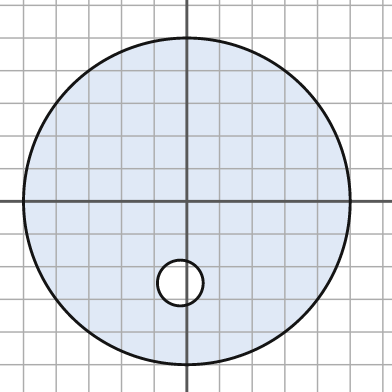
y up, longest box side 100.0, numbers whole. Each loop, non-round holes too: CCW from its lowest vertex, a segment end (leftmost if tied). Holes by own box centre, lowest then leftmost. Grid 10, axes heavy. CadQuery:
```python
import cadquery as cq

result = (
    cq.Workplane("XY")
    .moveTo(0.0, 0.0)
    .circle(50.0)
    .moveTo(-2.0, -25.0)
    .circle(7.0)
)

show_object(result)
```